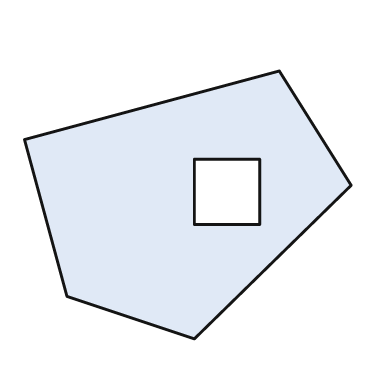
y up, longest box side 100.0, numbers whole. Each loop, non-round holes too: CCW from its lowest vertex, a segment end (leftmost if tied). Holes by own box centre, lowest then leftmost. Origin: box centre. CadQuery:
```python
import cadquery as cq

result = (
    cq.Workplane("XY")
    .moveTo(2.0, -41.0)
    .lineTo(50.0, 6.0)
    .lineTo(28.0, 41.0)
    .lineTo(-50.0, 20.0)
    .lineTo(-37.0, -28.0)
    .close()
    .moveTo(2.0, -6.0)
    .lineTo(22.0, -6.0)
    .lineTo(22.0, 14.0)
    .lineTo(2.0, 14.0)
    .close()
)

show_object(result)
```